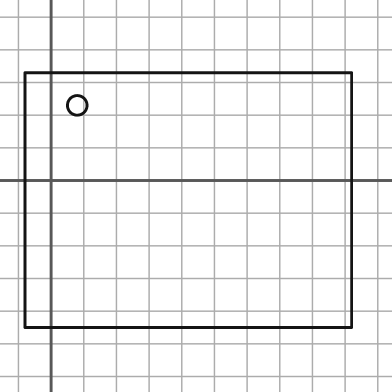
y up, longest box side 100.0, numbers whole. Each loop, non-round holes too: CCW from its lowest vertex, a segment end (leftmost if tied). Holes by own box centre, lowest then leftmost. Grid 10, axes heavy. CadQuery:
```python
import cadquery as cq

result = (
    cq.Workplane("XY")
    .moveTo(-8.0, -45.0)
    .lineTo(92.0, -45.0)
    .lineTo(92.0, 33.0)
    .lineTo(-8.0, 33.0)
    .close()
    .moveTo(8.0, 23.0)
    .circle(3.0)
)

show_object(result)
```